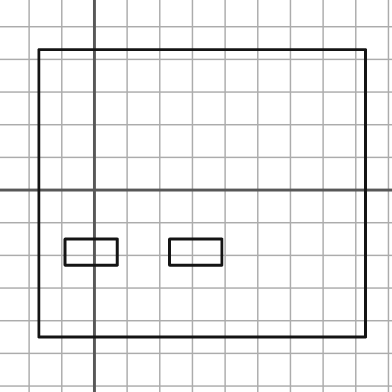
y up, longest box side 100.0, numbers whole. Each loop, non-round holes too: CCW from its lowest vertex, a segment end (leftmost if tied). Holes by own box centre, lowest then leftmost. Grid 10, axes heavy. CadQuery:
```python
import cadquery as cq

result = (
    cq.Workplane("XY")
    .moveTo(-17.0, -45.0)
    .lineTo(83.0, -45.0)
    .lineTo(83.0, 43.0)
    .lineTo(-17.0, 43.0)
    .close()
    .moveTo(-9.0, -23.0)
    .lineTo(7.0, -23.0)
    .lineTo(7.0, -15.0)
    .lineTo(-9.0, -15.0)
    .close()
    .moveTo(23.0, -23.0)
    .lineTo(39.0, -23.0)
    .lineTo(39.0, -15.0)
    .lineTo(23.0, -15.0)
    .close()
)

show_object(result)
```